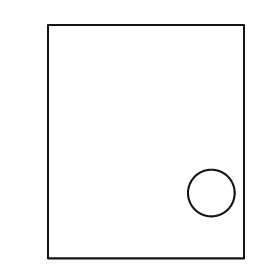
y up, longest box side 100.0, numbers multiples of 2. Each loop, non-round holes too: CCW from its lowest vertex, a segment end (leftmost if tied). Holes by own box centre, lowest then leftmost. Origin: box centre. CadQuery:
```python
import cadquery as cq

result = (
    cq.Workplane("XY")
    .moveTo(-42.0, -50.0)
    .lineTo(42.0, -50.0)
    .lineTo(42.0, 50.0)
    .lineTo(-42.0, 50.0)
    .close()
    .moveTo(28.0, -22.0)
    .circle(10.0)
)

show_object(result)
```